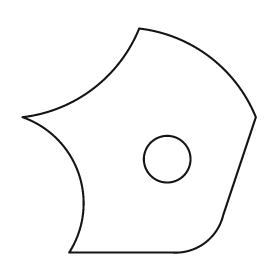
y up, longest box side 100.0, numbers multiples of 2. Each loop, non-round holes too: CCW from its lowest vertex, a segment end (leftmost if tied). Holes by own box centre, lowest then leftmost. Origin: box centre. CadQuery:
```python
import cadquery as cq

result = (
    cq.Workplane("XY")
    .moveTo(-30.0, -48.0)
    .lineTo(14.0, -48.0)
    .threePointArc((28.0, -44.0), (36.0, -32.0))
    .lineTo(50.0, 10.0)
    .threePointArc((30.0, 36.0), (0.0, 48.0))
    .threePointArc((-20.0, 22.0), (-50.0, 10.0))
    .threePointArc((-26.0, -14.0), (-30.0, -48.0))
    .close()
    .moveTo(12.0, -8.0)
    .circle(10.0)
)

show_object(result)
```